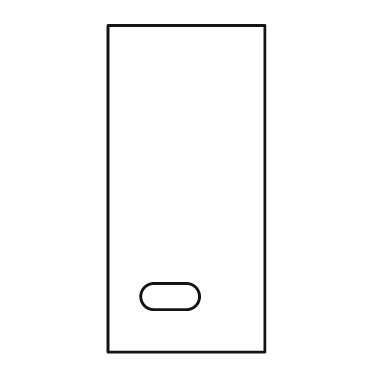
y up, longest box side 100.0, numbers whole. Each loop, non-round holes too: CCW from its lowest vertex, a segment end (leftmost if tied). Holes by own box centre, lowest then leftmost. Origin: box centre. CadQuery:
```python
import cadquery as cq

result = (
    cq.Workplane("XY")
    .moveTo(-24.0, -50.0)
    .lineTo(24.0, -50.0)
    .lineTo(24.0, 50.0)
    .lineTo(-24.0, 50.0)
    .close()
    .moveTo(-10.0, -37.0)
    .lineTo(0.0, -37.0)
    .threePointArc((4.0, -33.0), (0.0, -29.0))
    .lineTo(-10.0, -29.0)
    .threePointArc((-14.0, -33.0), (-10.0, -37.0))
    .close()
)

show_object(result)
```